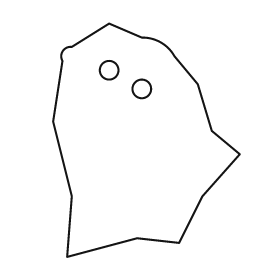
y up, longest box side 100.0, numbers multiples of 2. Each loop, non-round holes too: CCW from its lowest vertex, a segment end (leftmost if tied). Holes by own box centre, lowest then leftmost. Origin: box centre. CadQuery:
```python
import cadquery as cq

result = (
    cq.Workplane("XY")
    .moveTo(-34.0, -50.0)
    .lineTo(-4.0, -42.0)
    .lineTo(14.0, -44.0)
    .lineTo(24.0, -24.0)
    .lineTo(40.0, -6.0)
    .lineTo(28.0, 4.0)
    .lineTo(22.0, 24.0)
    .lineTo(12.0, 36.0)
    .threePointArc((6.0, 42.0), (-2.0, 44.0))
    .lineTo(-16.0, 50.0)
    .lineTo(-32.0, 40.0)
    .threePointArc((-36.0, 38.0), (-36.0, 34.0))
    .lineTo(-40.0, 8.0)
    .lineTo(-32.0, -24.0)
    .close()
    .moveTo(-2.0, 22.0)
    .circle(4.0)
    .moveTo(-16.0, 30.0)
    .circle(4.0)
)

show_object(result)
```